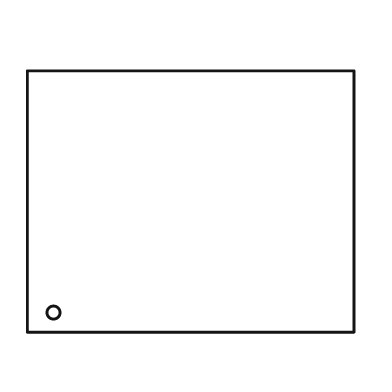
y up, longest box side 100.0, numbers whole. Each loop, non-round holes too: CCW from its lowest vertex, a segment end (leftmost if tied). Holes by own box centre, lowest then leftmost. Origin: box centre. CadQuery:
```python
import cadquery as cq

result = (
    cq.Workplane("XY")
    .moveTo(-50.0, -40.0)
    .lineTo(50.0, -40.0)
    .lineTo(50.0, 40.0)
    .lineTo(-50.0, 40.0)
    .close()
    .moveTo(-42.0, -34.0)
    .circle(2.0)
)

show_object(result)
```